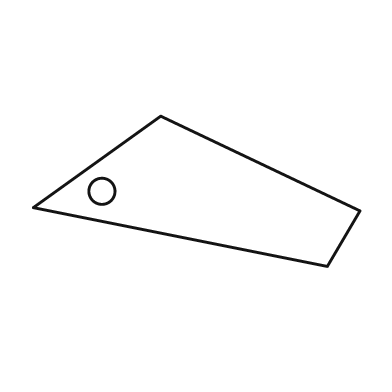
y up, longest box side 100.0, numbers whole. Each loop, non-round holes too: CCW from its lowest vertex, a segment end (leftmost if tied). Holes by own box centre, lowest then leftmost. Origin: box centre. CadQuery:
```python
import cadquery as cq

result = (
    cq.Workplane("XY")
    .moveTo(40.0, -23.0)
    .lineTo(50.0, -6.0)
    .lineTo(-11.0, 23.0)
    .lineTo(-50.0, -5.0)
    .close()
    .moveTo(-29.0, 0.0)
    .circle(4.0)
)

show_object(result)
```